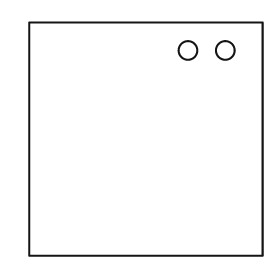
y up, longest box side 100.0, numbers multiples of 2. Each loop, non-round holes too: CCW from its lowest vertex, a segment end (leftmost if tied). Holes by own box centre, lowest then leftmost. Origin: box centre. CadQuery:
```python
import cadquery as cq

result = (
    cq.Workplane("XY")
    .moveTo(-50.0, -50.0)
    .lineTo(50.0, -50.0)
    .lineTo(50.0, 50.0)
    .lineTo(-50.0, 50.0)
    .close()
    .moveTo(18.0, 38.0)
    .circle(4.0)
    .moveTo(34.0, 38.0)
    .circle(4.0)
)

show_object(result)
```